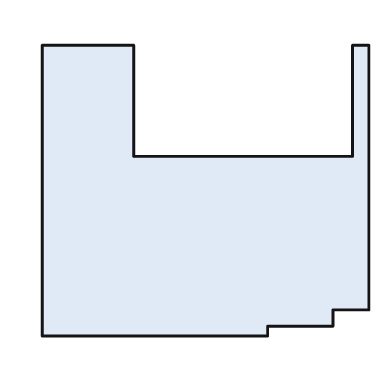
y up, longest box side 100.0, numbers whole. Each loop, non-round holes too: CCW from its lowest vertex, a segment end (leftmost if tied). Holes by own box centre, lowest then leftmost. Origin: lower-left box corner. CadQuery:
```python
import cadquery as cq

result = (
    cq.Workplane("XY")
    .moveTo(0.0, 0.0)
    .lineTo(69.0, 0.0)
    .lineTo(69.0, 3.0)
    .lineTo(89.0, 3.0)
    .lineTo(89.0, 8.0)
    .lineTo(100.0, 8.0)
    .lineTo(100.0, 89.0)
    .lineTo(95.0, 89.0)
    .lineTo(95.0, 55.0)
    .lineTo(28.0, 55.0)
    .lineTo(28.0, 89.0)
    .lineTo(0.0, 89.0)
    .close()
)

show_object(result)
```